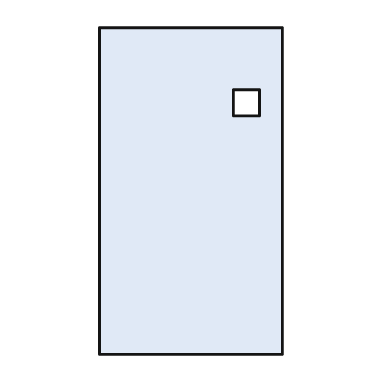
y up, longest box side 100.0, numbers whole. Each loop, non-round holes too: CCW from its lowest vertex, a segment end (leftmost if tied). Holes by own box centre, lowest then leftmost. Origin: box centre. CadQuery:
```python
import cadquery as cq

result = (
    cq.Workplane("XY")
    .moveTo(-28.0, -50.0)
    .lineTo(28.0, -50.0)
    .lineTo(28.0, 50.0)
    .lineTo(-28.0, 50.0)
    .close()
    .moveTo(13.0, 23.0)
    .lineTo(21.0, 23.0)
    .lineTo(21.0, 31.0)
    .lineTo(13.0, 31.0)
    .close()
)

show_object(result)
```